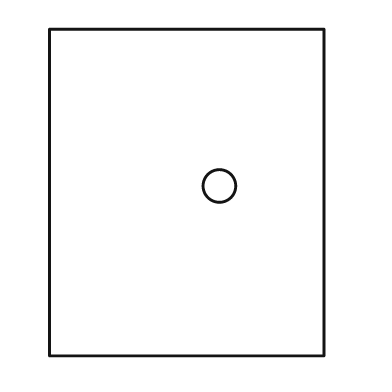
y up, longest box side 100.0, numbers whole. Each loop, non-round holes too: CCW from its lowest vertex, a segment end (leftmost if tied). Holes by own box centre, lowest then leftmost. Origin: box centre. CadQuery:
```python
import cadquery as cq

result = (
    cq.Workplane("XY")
    .moveTo(-42.0, -50.0)
    .lineTo(42.0, -50.0)
    .lineTo(42.0, 50.0)
    .lineTo(-42.0, 50.0)
    .close()
    .moveTo(10.0, 2.0)
    .circle(5.0)
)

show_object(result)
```